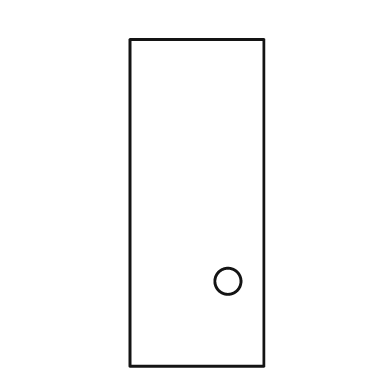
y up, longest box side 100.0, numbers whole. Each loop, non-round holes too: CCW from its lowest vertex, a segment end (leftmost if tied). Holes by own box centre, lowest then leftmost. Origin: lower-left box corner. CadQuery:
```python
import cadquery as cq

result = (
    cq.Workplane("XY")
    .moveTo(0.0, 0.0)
    .lineTo(41.0, 0.0)
    .lineTo(41.0, 100.0)
    .lineTo(0.0, 100.0)
    .close()
    .moveTo(30.0, 26.0)
    .circle(4.0)
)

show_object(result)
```